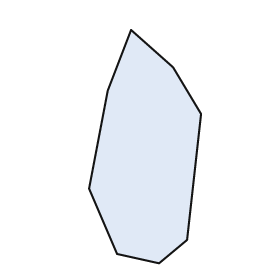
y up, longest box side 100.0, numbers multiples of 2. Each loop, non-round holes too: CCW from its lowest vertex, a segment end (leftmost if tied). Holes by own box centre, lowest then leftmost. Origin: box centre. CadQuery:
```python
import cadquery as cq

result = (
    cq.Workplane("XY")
    .moveTo(6.0, -50.0)
    .lineTo(18.0, -40.0)
    .lineTo(24.0, 14.0)
    .lineTo(12.0, 34.0)
    .lineTo(-6.0, 50.0)
    .lineTo(-16.0, 24.0)
    .lineTo(-24.0, -18.0)
    .lineTo(-12.0, -46.0)
    .close()
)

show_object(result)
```